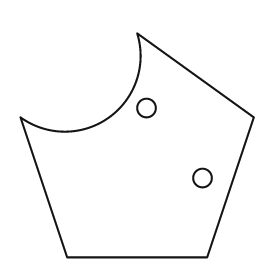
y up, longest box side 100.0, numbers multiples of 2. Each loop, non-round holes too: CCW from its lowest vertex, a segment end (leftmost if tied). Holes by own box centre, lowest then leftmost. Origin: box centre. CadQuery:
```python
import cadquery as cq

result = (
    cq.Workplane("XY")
    .moveTo(-30.0, -48.0)
    .lineTo(30.0, -48.0)
    .lineTo(50.0, 12.0)
    .lineTo(0.0, 48.0)
    .threePointArc((-12.0, 12.0), (-50.0, 12.0))
    .close()
    .moveTo(28.0, -14.0)
    .circle(4.0)
    .moveTo(4.0, 16.0)
    .circle(4.0)
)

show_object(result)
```